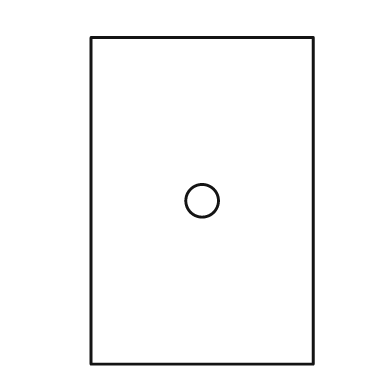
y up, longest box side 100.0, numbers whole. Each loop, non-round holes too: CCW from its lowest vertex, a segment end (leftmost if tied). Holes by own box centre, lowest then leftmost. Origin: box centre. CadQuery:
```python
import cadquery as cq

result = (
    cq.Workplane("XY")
    .moveTo(-34.0, -50.0)
    .lineTo(34.0, -50.0)
    .lineTo(34.0, 50.0)
    .lineTo(-34.0, 50.0)
    .close()
    .moveTo(0.0, 0.0)
    .circle(5.0)
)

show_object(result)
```